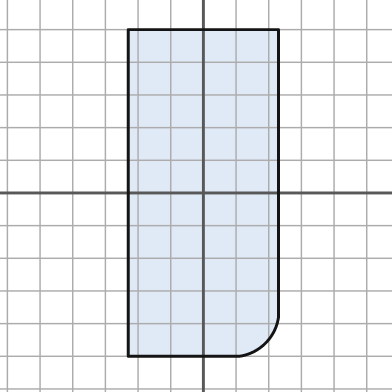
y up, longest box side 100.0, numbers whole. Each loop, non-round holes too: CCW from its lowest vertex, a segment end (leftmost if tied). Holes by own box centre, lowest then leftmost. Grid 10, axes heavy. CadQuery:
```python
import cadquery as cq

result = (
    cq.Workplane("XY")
    .moveTo(-23.0, -50.0)
    .lineTo(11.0, -50.0)
    .threePointArc((19.0, -46.0), (23.0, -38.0))
    .lineTo(23.0, 50.0)
    .lineTo(-23.0, 50.0)
    .close()
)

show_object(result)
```